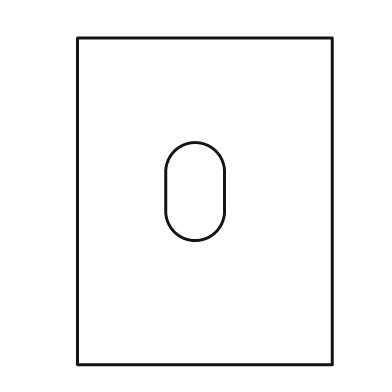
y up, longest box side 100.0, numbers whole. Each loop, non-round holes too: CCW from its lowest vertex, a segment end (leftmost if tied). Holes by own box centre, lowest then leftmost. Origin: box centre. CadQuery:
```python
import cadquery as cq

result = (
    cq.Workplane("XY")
    .moveTo(-39.0, -50.0)
    .lineTo(39.0, -50.0)
    .lineTo(39.0, 50.0)
    .lineTo(-39.0, 50.0)
    .close()
    .moveTo(-12.0, -3.0)
    .threePointArc((-3.0, -12.0), (6.0, -3.0))
    .lineTo(6.0, 9.0)
    .threePointArc((-3.0, 18.0), (-12.0, 9.0))
    .close()
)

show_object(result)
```